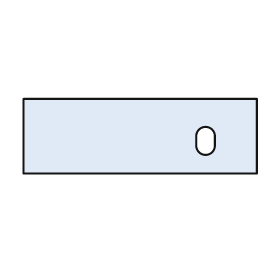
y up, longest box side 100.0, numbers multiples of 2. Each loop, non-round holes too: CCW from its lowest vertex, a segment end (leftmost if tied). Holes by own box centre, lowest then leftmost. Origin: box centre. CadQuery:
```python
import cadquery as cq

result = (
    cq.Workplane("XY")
    .moveTo(-50.0, -16.0)
    .lineTo(50.0, -16.0)
    .lineTo(50.0, 16.0)
    .lineTo(-50.0, 16.0)
    .close()
    .moveTo(24.0, -4.0)
    .threePointArc((28.0, -8.0), (32.0, -4.0))
    .lineTo(32.0, 0.0)
    .threePointArc((28.0, 4.0), (24.0, 0.0))
    .close()
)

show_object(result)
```